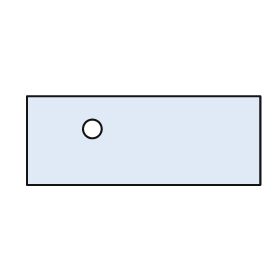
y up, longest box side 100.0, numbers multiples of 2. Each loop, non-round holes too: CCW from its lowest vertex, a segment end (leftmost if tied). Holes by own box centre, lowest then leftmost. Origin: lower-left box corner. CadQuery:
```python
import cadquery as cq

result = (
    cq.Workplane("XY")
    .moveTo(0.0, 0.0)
    .lineTo(100.0, 0.0)
    .lineTo(100.0, 38.0)
    .lineTo(0.0, 38.0)
    .close()
    .moveTo(28.0, 24.0)
    .circle(4.0)
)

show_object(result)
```